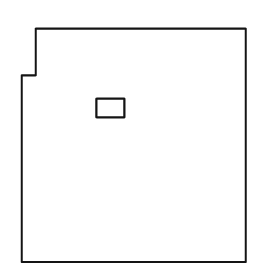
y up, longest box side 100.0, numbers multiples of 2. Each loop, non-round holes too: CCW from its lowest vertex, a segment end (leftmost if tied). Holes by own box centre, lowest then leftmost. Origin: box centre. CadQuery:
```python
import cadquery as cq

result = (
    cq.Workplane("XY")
    .moveTo(-48.0, -50.0)
    .lineTo(48.0, -50.0)
    .lineTo(48.0, 50.0)
    .lineTo(-42.0, 50.0)
    .lineTo(-42.0, 30.0)
    .lineTo(-48.0, 30.0)
    .close()
    .moveTo(-16.0, 12.0)
    .lineTo(-4.0, 12.0)
    .lineTo(-4.0, 20.0)
    .lineTo(-16.0, 20.0)
    .close()
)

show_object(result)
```